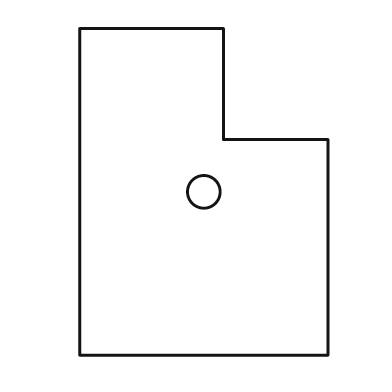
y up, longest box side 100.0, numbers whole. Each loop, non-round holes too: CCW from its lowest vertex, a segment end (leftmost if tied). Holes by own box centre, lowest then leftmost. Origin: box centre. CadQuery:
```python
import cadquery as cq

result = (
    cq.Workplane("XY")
    .moveTo(-38.0, -50.0)
    .lineTo(38.0, -50.0)
    .lineTo(38.0, 16.0)
    .lineTo(6.0, 16.0)
    .lineTo(6.0, 50.0)
    .lineTo(-38.0, 50.0)
    .close()
    .moveTo(0.0, 0.0)
    .circle(5.0)
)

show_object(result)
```